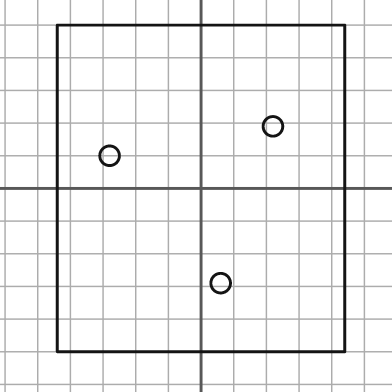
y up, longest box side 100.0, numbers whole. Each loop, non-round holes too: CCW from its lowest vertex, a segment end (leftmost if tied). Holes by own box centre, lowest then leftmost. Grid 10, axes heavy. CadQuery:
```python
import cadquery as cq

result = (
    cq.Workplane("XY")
    .moveTo(-44.0, -50.0)
    .lineTo(44.0, -50.0)
    .lineTo(44.0, 50.0)
    .lineTo(-44.0, 50.0)
    .close()
    .moveTo(6.0, -29.0)
    .circle(3.0)
    .moveTo(-28.0, 10.0)
    .circle(3.0)
    .moveTo(22.0, 19.0)
    .circle(3.0)
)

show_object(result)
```